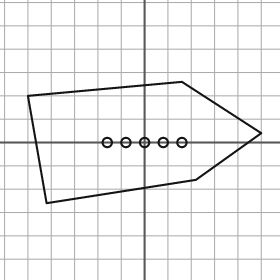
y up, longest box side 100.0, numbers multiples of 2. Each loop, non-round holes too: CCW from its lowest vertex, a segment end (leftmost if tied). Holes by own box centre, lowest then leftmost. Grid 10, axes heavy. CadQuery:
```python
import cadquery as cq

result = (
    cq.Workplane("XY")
    .moveTo(-42.0, -26.0)
    .lineTo(22.0, -16.0)
    .lineTo(50.0, 4.0)
    .lineTo(16.0, 26.0)
    .lineTo(-50.0, 20.0)
    .close()
    .moveTo(-16.0, 0.0)
    .circle(2.0)
    .moveTo(-8.0, 0.0)
    .circle(2.0)
    .moveTo(0.0, 0.0)
    .circle(2.0)
    .moveTo(8.0, 0.0)
    .circle(2.0)
    .moveTo(16.0, 0.0)
    .circle(2.0)
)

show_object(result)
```